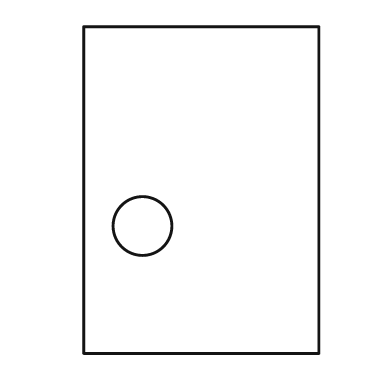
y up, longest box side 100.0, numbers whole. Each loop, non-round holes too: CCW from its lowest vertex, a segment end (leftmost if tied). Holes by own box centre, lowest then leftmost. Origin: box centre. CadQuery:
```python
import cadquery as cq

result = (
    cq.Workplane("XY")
    .moveTo(-36.0, -50.0)
    .lineTo(36.0, -50.0)
    .lineTo(36.0, 50.0)
    .lineTo(-36.0, 50.0)
    .close()
    .moveTo(-18.0, -11.0)
    .circle(9.0)
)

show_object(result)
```